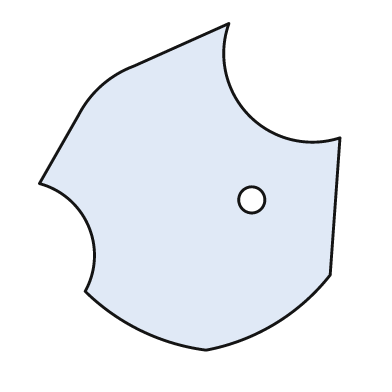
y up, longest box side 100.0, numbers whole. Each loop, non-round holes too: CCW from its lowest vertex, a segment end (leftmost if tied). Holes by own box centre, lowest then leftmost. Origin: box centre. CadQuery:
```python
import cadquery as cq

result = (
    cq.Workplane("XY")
    .moveTo(5.0, -50.0)
    .threePointArc((26.0, -42.0), (43.0, -27.0))
    .lineTo(46.0, 15.0)
    .threePointArc((18.0, 22.0), (12.0, 50.0))
    .lineTo(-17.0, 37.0)
    .threePointArc((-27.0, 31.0), (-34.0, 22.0))
    .lineTo(-46.0, 1.0)
    .threePointArc((-31.0, -12.0), (-32.0, -32.0))
    .threePointArc((-15.0, -44.0), (5.0, -50.0))
    .close()
    .moveTo(19.0, -4.0)
    .circle(4.0)
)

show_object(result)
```